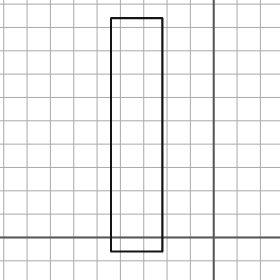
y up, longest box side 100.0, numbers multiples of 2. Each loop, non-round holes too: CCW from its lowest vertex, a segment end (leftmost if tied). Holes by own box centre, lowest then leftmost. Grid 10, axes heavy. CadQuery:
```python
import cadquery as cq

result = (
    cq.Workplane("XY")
    .moveTo(-44.0, -6.0)
    .lineTo(-22.0, -6.0)
    .lineTo(-22.0, 94.0)
    .lineTo(-44.0, 94.0)
    .close()
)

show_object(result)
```